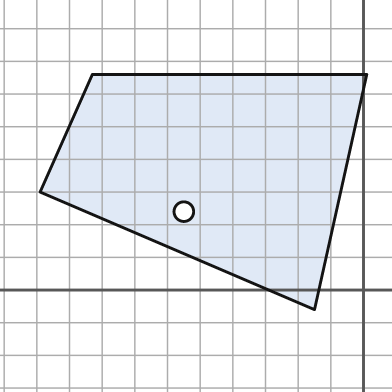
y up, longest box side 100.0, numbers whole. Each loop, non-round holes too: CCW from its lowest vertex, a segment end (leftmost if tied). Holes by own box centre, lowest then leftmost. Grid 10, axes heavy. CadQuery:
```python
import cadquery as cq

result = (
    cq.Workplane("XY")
    .moveTo(-15.0, -6.0)
    .lineTo(1.0, 66.0)
    .lineTo(-83.0, 66.0)
    .lineTo(-99.0, 30.0)
    .close()
    .moveTo(-55.0, 24.0)
    .circle(3.0)
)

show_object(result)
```